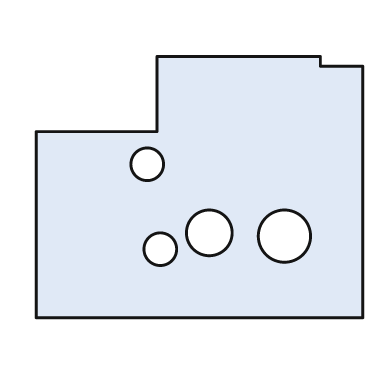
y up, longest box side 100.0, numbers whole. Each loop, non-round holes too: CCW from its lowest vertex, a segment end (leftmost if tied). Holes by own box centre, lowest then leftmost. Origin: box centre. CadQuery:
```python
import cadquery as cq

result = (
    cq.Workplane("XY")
    .moveTo(-50.0, -40.0)
    .lineTo(50.0, -40.0)
    .lineTo(50.0, 37.0)
    .lineTo(37.0, 37.0)
    .lineTo(37.0, 40.0)
    .lineTo(-13.0, 40.0)
    .lineTo(-13.0, 17.0)
    .lineTo(-50.0, 17.0)
    .close()
    .moveTo(-12.0, -19.0)
    .circle(5.0)
    .moveTo(26.0, -15.0)
    .circle(8.0)
    .moveTo(3.0, -14.0)
    .circle(7.0)
    .moveTo(-16.0, 7.0)
    .circle(5.0)
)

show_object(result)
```